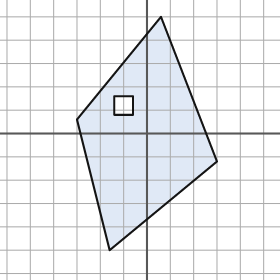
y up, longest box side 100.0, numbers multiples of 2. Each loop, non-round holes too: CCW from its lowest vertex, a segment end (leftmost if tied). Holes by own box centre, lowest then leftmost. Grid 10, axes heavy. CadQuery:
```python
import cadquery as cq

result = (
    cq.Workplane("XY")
    .moveTo(-16.0, -50.0)
    .lineTo(30.0, -12.0)
    .lineTo(6.0, 50.0)
    .lineTo(-30.0, 6.0)
    .close()
    .moveTo(-14.0, 8.0)
    .lineTo(-6.0, 8.0)
    .lineTo(-6.0, 16.0)
    .lineTo(-14.0, 16.0)
    .close()
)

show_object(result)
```